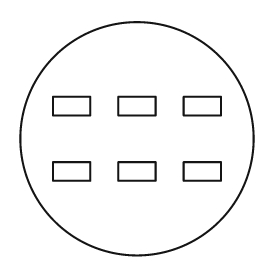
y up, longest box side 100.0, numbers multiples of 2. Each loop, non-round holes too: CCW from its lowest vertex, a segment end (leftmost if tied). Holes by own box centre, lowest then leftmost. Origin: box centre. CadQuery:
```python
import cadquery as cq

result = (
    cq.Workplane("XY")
    .moveTo(0.0, 0.0)
    .circle(50.0)
    .moveTo(-36.0, -18.0)
    .lineTo(-20.0, -18.0)
    .lineTo(-20.0, -10.0)
    .lineTo(-36.0, -10.0)
    .close()
    .moveTo(-8.0, -18.0)
    .lineTo(8.0, -18.0)
    .lineTo(8.0, -10.0)
    .lineTo(-8.0, -10.0)
    .close()
    .moveTo(20.0, -18.0)
    .lineTo(36.0, -18.0)
    .lineTo(36.0, -10.0)
    .lineTo(20.0, -10.0)
    .close()
    .moveTo(-36.0, 10.0)
    .lineTo(-20.0, 10.0)
    .lineTo(-20.0, 18.0)
    .lineTo(-36.0, 18.0)
    .close()
    .moveTo(-8.0, 10.0)
    .lineTo(8.0, 10.0)
    .lineTo(8.0, 18.0)
    .lineTo(-8.0, 18.0)
    .close()
    .moveTo(20.0, 10.0)
    .lineTo(36.0, 10.0)
    .lineTo(36.0, 18.0)
    .lineTo(20.0, 18.0)
    .close()
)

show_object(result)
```